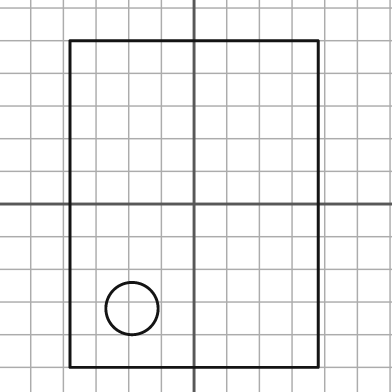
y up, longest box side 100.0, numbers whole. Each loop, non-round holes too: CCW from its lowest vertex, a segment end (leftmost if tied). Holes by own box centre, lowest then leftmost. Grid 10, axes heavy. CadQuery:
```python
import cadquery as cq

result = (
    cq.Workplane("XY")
    .moveTo(-38.0, -50.0)
    .lineTo(38.0, -50.0)
    .lineTo(38.0, 50.0)
    .lineTo(-38.0, 50.0)
    .close()
    .moveTo(-19.0, -32.0)
    .circle(8.0)
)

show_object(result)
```